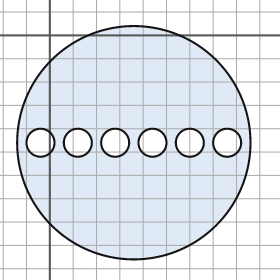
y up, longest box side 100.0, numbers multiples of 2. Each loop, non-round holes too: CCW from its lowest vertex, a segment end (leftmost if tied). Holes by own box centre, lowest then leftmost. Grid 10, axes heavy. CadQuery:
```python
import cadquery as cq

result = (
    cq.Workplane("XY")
    .moveTo(36.0, -46.0)
    .circle(50.0)
    .moveTo(-4.0, -46.0)
    .circle(6.0)
    .moveTo(12.0, -46.0)
    .circle(6.0)
    .moveTo(28.0, -46.0)
    .circle(6.0)
    .moveTo(44.0, -46.0)
    .circle(6.0)
    .moveTo(60.0, -46.0)
    .circle(6.0)
    .moveTo(76.0, -46.0)
    .circle(6.0)
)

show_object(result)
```